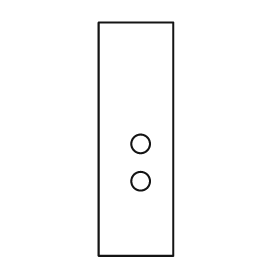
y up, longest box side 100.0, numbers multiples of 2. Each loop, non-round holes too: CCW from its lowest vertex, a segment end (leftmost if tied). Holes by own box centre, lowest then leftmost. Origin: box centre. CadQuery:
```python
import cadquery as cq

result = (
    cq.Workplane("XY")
    .moveTo(-16.0, -50.0)
    .lineTo(16.0, -50.0)
    .lineTo(16.0, 50.0)
    .lineTo(-16.0, 50.0)
    .close()
    .moveTo(2.0, -18.0)
    .circle(4.0)
    .moveTo(2.0, -2.0)
    .circle(4.0)
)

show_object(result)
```